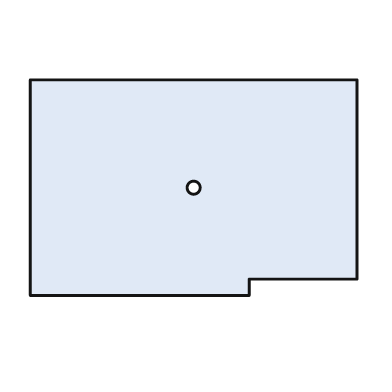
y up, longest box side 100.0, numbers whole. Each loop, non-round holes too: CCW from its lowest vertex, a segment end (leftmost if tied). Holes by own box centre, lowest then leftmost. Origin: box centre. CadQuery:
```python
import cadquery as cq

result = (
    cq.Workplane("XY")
    .moveTo(-50.0, -33.0)
    .lineTo(17.0, -33.0)
    .lineTo(17.0, -28.0)
    .lineTo(50.0, -28.0)
    .lineTo(50.0, 33.0)
    .lineTo(-50.0, 33.0)
    .close()
    .moveTo(0.0, 0.0)
    .circle(2.0)
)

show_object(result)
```